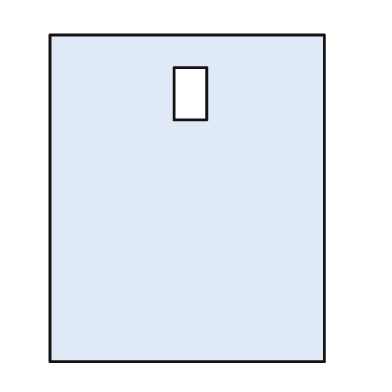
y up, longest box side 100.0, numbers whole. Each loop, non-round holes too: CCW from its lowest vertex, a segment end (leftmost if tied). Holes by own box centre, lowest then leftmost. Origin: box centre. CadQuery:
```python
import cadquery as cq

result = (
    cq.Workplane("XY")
    .moveTo(-42.0, -50.0)
    .lineTo(42.0, -50.0)
    .lineTo(42.0, 50.0)
    .lineTo(-42.0, 50.0)
    .close()
    .moveTo(-4.0, 24.0)
    .lineTo(6.0, 24.0)
    .lineTo(6.0, 40.0)
    .lineTo(-4.0, 40.0)
    .close()
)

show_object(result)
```